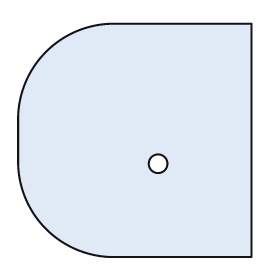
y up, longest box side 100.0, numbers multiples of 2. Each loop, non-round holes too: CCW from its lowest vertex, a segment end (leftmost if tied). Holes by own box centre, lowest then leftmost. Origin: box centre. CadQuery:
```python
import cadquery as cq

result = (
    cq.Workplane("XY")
    .moveTo(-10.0, -50.0)
    .lineTo(50.0, -50.0)
    .lineTo(50.0, 50.0)
    .lineTo(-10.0, 50.0)
    .threePointArc((-38.0, 38.0), (-50.0, 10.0))
    .lineTo(-50.0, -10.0)
    .threePointArc((-38.0, -38.0), (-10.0, -50.0))
    .close()
    .moveTo(10.0, -10.0)
    .circle(4.0)
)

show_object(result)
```